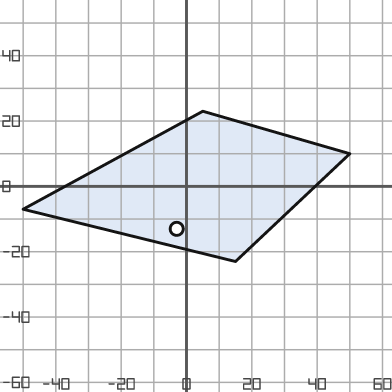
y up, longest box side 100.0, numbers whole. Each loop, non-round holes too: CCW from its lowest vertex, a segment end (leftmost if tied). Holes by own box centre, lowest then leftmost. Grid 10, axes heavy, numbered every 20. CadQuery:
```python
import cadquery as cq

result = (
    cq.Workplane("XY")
    .moveTo(15.0, -23.0)
    .lineTo(50.0, 10.0)
    .lineTo(5.0, 23.0)
    .lineTo(-50.0, -7.0)
    .close()
    .moveTo(-3.0, -13.0)
    .circle(2.0)
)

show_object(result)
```